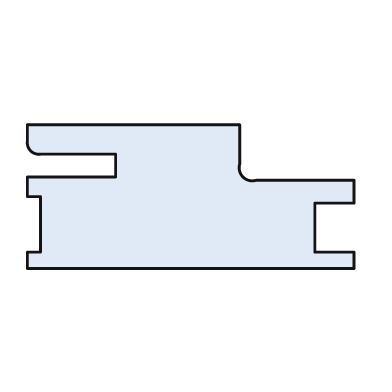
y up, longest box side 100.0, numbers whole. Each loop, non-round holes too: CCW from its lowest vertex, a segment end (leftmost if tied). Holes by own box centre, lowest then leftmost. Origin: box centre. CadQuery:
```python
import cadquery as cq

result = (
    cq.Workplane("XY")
    .moveTo(-50.0, -22.0)
    .lineTo(50.0, -22.0)
    .lineTo(50.0, -17.0)
    .lineTo(38.0, -17.0)
    .lineTo(38.0, -2.0)
    .lineTo(50.0, -2.0)
    .lineTo(50.0, 5.0)
    .lineTo(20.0, 5.0)
    .threePointArc((16.0, 6.0), (15.0, 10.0))
    .lineTo(15.0, 22.0)
    .lineTo(-50.0, 22.0)
    .lineTo(-50.0, 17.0)
    .threePointArc((-49.0, 14.0), (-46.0, 13.0))
    .lineTo(-23.0, 13.0)
    .lineTo(-23.0, 6.0)
    .lineTo(-50.0, 6.0)
    .lineTo(-50.0, 0.0)
    .lineTo(-46.0, 0.0)
    .lineTo(-46.0, -17.0)
    .lineTo(-50.0, -17.0)
    .close()
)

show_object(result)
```